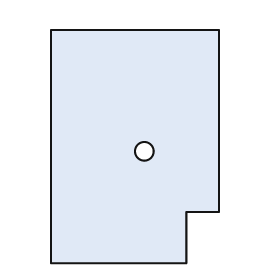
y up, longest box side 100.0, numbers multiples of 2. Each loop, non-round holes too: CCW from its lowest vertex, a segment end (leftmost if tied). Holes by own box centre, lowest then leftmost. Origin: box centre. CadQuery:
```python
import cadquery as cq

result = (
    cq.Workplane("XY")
    .moveTo(-36.0, -50.0)
    .lineTo(22.0, -50.0)
    .lineTo(22.0, -28.0)
    .lineTo(36.0, -28.0)
    .lineTo(36.0, 50.0)
    .lineTo(-36.0, 50.0)
    .close()
    .moveTo(4.0, -2.0)
    .circle(4.0)
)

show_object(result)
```